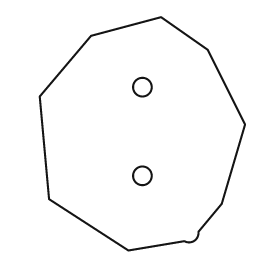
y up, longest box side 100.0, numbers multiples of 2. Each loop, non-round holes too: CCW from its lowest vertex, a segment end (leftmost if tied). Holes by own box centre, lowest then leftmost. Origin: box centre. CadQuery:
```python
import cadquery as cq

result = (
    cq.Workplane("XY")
    .moveTo(-6.0, -50.0)
    .lineTo(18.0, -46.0)
    .threePointArc((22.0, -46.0), (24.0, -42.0))
    .lineTo(34.0, -30.0)
    .lineTo(44.0, 4.0)
    .lineTo(28.0, 36.0)
    .lineTo(8.0, 50.0)
    .lineTo(-22.0, 42.0)
    .lineTo(-44.0, 16.0)
    .lineTo(-40.0, -28.0)
    .close()
    .moveTo(0.0, -18.0)
    .circle(4.0)
    .moveTo(0.0, 20.0)
    .circle(4.0)
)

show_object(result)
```